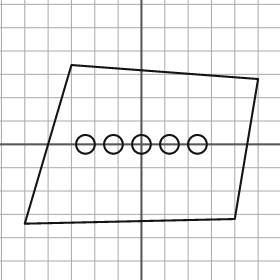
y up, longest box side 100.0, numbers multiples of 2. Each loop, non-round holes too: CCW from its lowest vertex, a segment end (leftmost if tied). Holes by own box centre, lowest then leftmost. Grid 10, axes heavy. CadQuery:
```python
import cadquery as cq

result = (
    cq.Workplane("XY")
    .moveTo(-50.0, -34.0)
    .lineTo(40.0, -32.0)
    .lineTo(50.0, 28.0)
    .lineTo(-30.0, 34.0)
    .close()
    .moveTo(-24.0, 0.0)
    .circle(4.0)
    .moveTo(-12.0, 0.0)
    .circle(4.0)
    .moveTo(0.0, 0.0)
    .circle(4.0)
    .moveTo(12.0, 0.0)
    .circle(4.0)
    .moveTo(24.0, 0.0)
    .circle(4.0)
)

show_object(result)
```